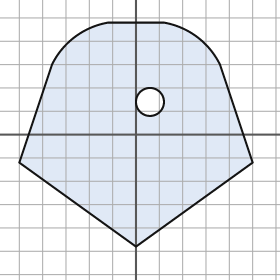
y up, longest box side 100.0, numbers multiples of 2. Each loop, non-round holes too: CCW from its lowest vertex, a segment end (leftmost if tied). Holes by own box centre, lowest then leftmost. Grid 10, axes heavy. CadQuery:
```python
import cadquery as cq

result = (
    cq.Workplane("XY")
    .moveTo(0.0, -48.0)
    .lineTo(50.0, -12.0)
    .lineTo(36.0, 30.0)
    .threePointArc((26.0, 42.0), (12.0, 48.0))
    .lineTo(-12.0, 48.0)
    .threePointArc((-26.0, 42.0), (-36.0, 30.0))
    .lineTo(-50.0, -12.0)
    .close()
    .moveTo(6.0, 14.0)
    .circle(6.0)
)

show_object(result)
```